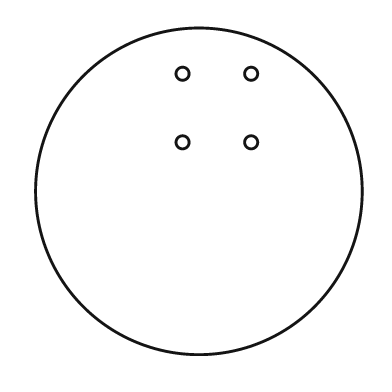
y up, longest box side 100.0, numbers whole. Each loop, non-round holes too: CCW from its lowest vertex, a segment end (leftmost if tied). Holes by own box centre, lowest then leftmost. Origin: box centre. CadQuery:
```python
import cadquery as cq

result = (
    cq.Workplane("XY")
    .moveTo(0.0, 0.0)
    .circle(50.0)
    .moveTo(-5.0, 15.0)
    .circle(2.0)
    .moveTo(16.0, 15.0)
    .circle(2.0)
    .moveTo(-5.0, 36.0)
    .circle(2.0)
    .moveTo(16.0, 36.0)
    .circle(2.0)
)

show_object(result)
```